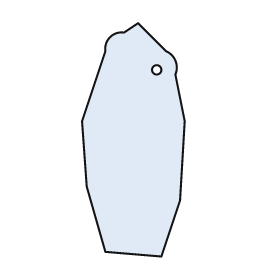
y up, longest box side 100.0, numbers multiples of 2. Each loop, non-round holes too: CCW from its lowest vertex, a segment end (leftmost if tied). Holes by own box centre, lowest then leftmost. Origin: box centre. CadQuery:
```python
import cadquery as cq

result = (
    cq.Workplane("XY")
    .moveTo(12.0, -50.0)
    .lineTo(20.0, -26.0)
    .lineTo(22.0, 8.0)
    .lineTo(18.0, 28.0)
    .threePointArc((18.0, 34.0), (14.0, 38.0))
    .lineTo(2.0, 50.0)
    .lineTo(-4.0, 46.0)
    .threePointArc((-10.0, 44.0), (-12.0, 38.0))
    .lineTo(-22.0, 8.0)
    .lineTo(-20.0, -20.0)
    .lineTo(-12.0, -48.0)
    .close()
    .moveTo(10.0, 30.0)
    .circle(2.0)
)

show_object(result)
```